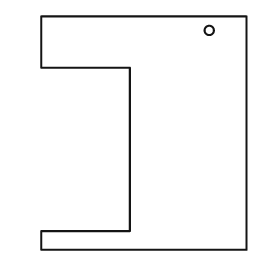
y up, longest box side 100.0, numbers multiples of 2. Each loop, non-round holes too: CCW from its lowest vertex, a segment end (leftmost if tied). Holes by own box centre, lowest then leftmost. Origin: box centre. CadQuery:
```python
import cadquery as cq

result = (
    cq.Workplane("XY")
    .moveTo(-44.0, -50.0)
    .lineTo(44.0, -50.0)
    .lineTo(44.0, 50.0)
    .lineTo(-44.0, 50.0)
    .lineTo(-44.0, 28.0)
    .lineTo(-6.0, 28.0)
    .lineTo(-6.0, -42.0)
    .lineTo(-44.0, -42.0)
    .close()
    .moveTo(28.0, 44.0)
    .circle(2.0)
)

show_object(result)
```